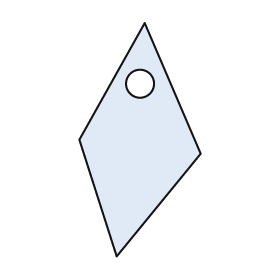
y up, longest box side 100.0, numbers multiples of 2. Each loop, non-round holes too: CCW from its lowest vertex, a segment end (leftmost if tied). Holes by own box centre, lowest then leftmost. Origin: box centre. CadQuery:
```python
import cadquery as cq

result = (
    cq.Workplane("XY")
    .moveTo(-10.0, -50.0)
    .lineTo(26.0, -6.0)
    .lineTo(2.0, 50.0)
    .lineTo(-26.0, 0.0)
    .close()
    .moveTo(0.0, 24.0)
    .circle(6.0)
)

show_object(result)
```